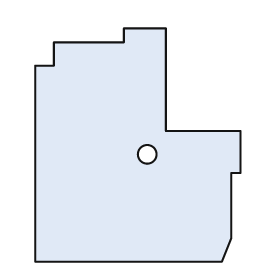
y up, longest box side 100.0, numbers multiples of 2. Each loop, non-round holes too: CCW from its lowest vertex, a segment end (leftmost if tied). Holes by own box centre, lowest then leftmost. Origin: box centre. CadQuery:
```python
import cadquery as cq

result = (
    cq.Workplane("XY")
    .moveTo(-44.0, -50.0)
    .lineTo(36.0, -50.0)
    .lineTo(40.0, -40.0)
    .lineTo(40.0, -12.0)
    .lineTo(44.0, -12.0)
    .lineTo(44.0, 6.0)
    .lineTo(12.0, 6.0)
    .lineTo(12.0, 50.0)
    .lineTo(-6.0, 50.0)
    .lineTo(-6.0, 44.0)
    .lineTo(-36.0, 44.0)
    .lineTo(-36.0, 34.0)
    .lineTo(-44.0, 34.0)
    .close()
    .moveTo(4.0, -4.0)
    .circle(4.0)
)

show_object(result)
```